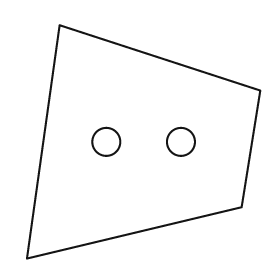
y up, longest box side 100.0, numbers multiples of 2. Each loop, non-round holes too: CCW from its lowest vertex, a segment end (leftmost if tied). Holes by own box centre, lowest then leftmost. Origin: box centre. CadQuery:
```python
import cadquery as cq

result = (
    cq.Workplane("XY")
    .moveTo(-50.0, -50.0)
    .lineTo(42.0, -28.0)
    .lineTo(50.0, 22.0)
    .lineTo(-36.0, 50.0)
    .close()
    .moveTo(-16.0, 0.0)
    .circle(6.0)
    .moveTo(16.0, 0.0)
    .circle(6.0)
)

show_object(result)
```